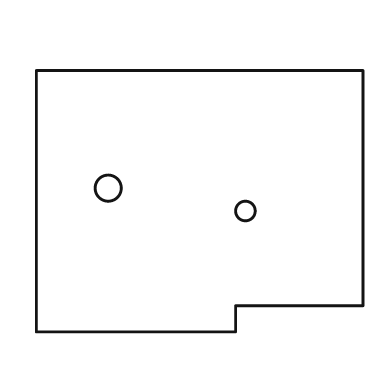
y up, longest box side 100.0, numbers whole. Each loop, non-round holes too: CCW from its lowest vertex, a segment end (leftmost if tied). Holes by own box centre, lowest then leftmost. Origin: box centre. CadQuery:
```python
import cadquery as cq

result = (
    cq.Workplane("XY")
    .moveTo(-50.0, -40.0)
    .lineTo(11.0, -40.0)
    .lineTo(11.0, -32.0)
    .lineTo(50.0, -32.0)
    .lineTo(50.0, 40.0)
    .lineTo(-50.0, 40.0)
    .close()
    .moveTo(14.0, -3.0)
    .circle(3.0)
    .moveTo(-28.0, 4.0)
    .circle(4.0)
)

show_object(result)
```